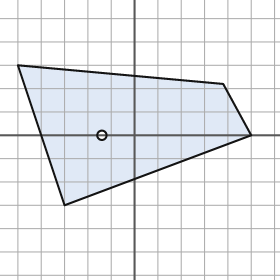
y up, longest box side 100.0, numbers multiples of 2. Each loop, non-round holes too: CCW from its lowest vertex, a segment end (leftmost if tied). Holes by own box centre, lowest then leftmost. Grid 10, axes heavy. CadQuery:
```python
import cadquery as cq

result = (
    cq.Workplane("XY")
    .moveTo(-30.0, -30.0)
    .lineTo(50.0, 0.0)
    .lineTo(38.0, 22.0)
    .lineTo(-50.0, 30.0)
    .close()
    .moveTo(-14.0, 0.0)
    .circle(2.0)
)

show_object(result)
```